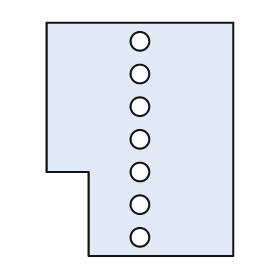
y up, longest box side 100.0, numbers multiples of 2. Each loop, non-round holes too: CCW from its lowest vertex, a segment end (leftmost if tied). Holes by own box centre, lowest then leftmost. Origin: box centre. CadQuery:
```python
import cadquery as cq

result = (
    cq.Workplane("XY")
    .moveTo(-22.0, -50.0)
    .lineTo(40.0, -50.0)
    .lineTo(40.0, 50.0)
    .lineTo(-40.0, 50.0)
    .lineTo(-40.0, -14.0)
    .lineTo(-22.0, -14.0)
    .close()
    .moveTo(0.0, -42.0)
    .circle(4.0)
    .moveTo(0.0, -28.0)
    .circle(4.0)
    .moveTo(0.0, -14.0)
    .circle(4.0)
    .moveTo(0.0, 0.0)
    .circle(4.0)
    .moveTo(0.0, 14.0)
    .circle(4.0)
    .moveTo(0.0, 28.0)
    .circle(4.0)
    .moveTo(0.0, 42.0)
    .circle(4.0)
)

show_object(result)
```